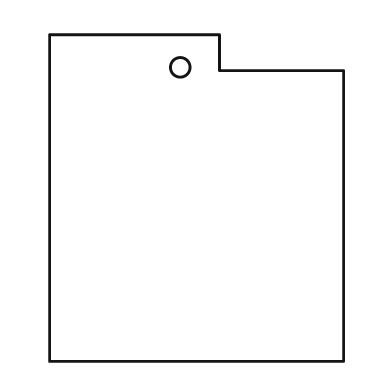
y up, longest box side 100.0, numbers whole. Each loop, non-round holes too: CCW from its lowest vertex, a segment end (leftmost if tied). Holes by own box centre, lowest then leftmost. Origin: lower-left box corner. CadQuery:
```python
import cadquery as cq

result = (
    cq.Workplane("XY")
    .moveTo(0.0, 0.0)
    .lineTo(90.0, 0.0)
    .lineTo(90.0, 89.0)
    .lineTo(52.0, 89.0)
    .lineTo(52.0, 100.0)
    .lineTo(0.0, 100.0)
    .close()
    .moveTo(40.0, 90.0)
    .circle(3.0)
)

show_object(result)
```